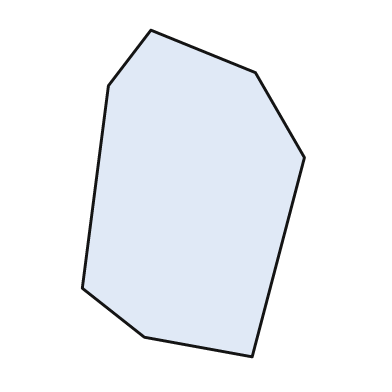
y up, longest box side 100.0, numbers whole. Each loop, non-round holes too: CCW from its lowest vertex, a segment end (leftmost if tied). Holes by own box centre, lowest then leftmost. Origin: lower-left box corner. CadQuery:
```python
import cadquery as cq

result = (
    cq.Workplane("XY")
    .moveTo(52.0, 0.0)
    .lineTo(68.0, 61.0)
    .lineTo(53.0, 87.0)
    .lineTo(21.0, 100.0)
    .lineTo(8.0, 83.0)
    .lineTo(0.0, 21.0)
    .lineTo(19.0, 6.0)
    .close()
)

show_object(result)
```